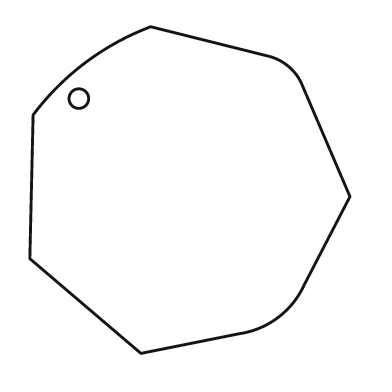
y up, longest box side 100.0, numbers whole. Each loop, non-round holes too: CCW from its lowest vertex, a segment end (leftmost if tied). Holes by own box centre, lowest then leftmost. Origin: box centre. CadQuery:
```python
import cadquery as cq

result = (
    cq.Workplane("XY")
    .moveTo(-15.0, -50.0)
    .lineTo(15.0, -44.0)
    .threePointArc((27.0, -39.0), (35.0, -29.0))
    .lineTo(49.0, -2.0)
    .lineTo(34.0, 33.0)
    .threePointArc((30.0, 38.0), (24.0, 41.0))
    .lineTo(-12.0, 50.0)
    .threePointArc((-32.0, 39.0), (-48.0, 23.0))
    .lineTo(-49.0, -21.0)
    .close()
    .moveTo(-34.0, 28.0)
    .circle(3.0)
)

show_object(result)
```